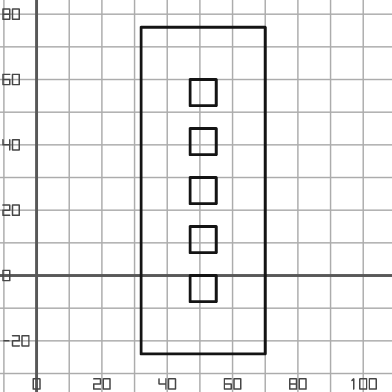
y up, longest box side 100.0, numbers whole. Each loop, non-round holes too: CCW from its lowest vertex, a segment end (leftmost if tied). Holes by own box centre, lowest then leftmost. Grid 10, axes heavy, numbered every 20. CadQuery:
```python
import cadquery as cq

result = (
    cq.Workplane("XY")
    .moveTo(32.0, -24.0)
    .lineTo(70.0, -24.0)
    .lineTo(70.0, 76.0)
    .lineTo(32.0, 76.0)
    .close()
    .moveTo(47.0, -8.0)
    .lineTo(55.0, -8.0)
    .lineTo(55.0, 0.0)
    .lineTo(47.0, 0.0)
    .close()
    .moveTo(47.0, 7.0)
    .lineTo(55.0, 7.0)
    .lineTo(55.0, 15.0)
    .lineTo(47.0, 15.0)
    .close()
    .moveTo(47.0, 22.0)
    .lineTo(55.0, 22.0)
    .lineTo(55.0, 30.0)
    .lineTo(47.0, 30.0)
    .close()
    .moveTo(47.0, 37.0)
    .lineTo(55.0, 37.0)
    .lineTo(55.0, 45.0)
    .lineTo(47.0, 45.0)
    .close()
    .moveTo(47.0, 52.0)
    .lineTo(55.0, 52.0)
    .lineTo(55.0, 60.0)
    .lineTo(47.0, 60.0)
    .close()
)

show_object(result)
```